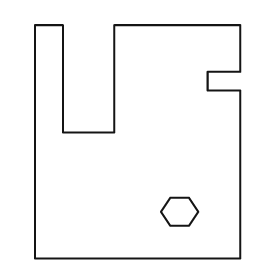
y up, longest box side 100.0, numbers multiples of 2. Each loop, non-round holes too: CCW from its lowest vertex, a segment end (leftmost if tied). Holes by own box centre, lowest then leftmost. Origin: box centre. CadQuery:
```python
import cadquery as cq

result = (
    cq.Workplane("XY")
    .moveTo(-44.0, -50.0)
    .lineTo(44.0, -50.0)
    .lineTo(44.0, 22.0)
    .lineTo(30.0, 22.0)
    .lineTo(30.0, 30.0)
    .lineTo(44.0, 30.0)
    .lineTo(44.0, 50.0)
    .lineTo(-10.0, 50.0)
    .lineTo(-10.0, 4.0)
    .lineTo(-32.0, 4.0)
    .lineTo(-32.0, 50.0)
    .lineTo(-44.0, 50.0)
    .close()
    .moveTo(14.0, -36.0)
    .lineTo(22.0, -36.0)
    .lineTo(26.0, -30.0)
    .lineTo(22.0, -24.0)
    .lineTo(14.0, -24.0)
    .lineTo(10.0, -30.0)
    .close()
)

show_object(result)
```